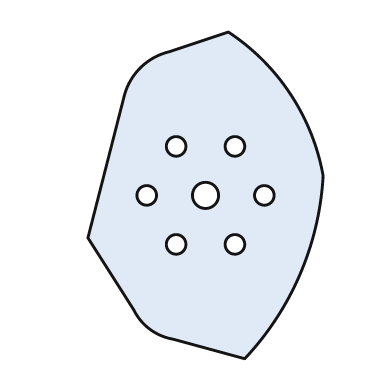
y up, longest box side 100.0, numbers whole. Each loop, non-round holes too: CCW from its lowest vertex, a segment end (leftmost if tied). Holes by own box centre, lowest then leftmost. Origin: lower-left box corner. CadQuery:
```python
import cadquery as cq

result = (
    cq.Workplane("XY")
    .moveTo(48.0, 0.0)
    .threePointArc((65.0, 26.0), (72.0, 56.0))
    .threePointArc((62.0, 81.0), (43.0, 100.0))
    .lineTo(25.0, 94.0)
    .threePointArc((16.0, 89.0), (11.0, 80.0))
    .lineTo(0.0, 37.0)
    .lineTo(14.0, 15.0)
    .threePointArc((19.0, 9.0), (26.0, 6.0))
    .close()
    .moveTo(27.0, 35.0)
    .circle(3.0)
    .moveTo(45.0, 35.0)
    .circle(3.0)
    .moveTo(18.0, 50.0)
    .circle(3.0)
    .moveTo(36.0, 50.0)
    .circle(4.0)
    .moveTo(54.0, 50.0)
    .circle(3.0)
    .moveTo(27.0, 65.0)
    .circle(3.0)
    .moveTo(45.0, 65.0)
    .circle(3.0)
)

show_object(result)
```